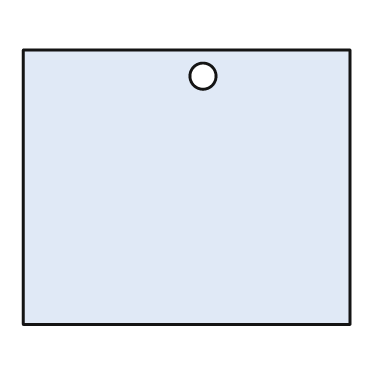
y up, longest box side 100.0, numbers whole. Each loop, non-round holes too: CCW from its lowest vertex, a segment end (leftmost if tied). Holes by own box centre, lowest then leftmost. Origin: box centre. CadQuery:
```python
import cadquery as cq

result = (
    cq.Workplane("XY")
    .moveTo(-50.0, -42.0)
    .lineTo(50.0, -42.0)
    .lineTo(50.0, 42.0)
    .lineTo(-50.0, 42.0)
    .close()
    .moveTo(5.0, 34.0)
    .circle(4.0)
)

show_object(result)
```